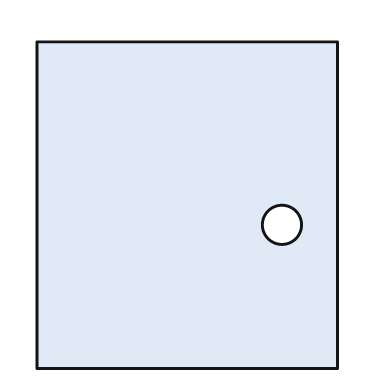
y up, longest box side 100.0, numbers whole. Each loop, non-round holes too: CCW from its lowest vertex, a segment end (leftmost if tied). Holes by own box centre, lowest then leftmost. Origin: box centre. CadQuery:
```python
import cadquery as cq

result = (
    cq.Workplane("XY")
    .moveTo(-46.0, -50.0)
    .lineTo(46.0, -50.0)
    .lineTo(46.0, 50.0)
    .lineTo(-46.0, 50.0)
    .close()
    .moveTo(29.0, -6.0)
    .circle(6.0)
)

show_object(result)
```